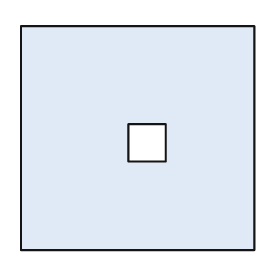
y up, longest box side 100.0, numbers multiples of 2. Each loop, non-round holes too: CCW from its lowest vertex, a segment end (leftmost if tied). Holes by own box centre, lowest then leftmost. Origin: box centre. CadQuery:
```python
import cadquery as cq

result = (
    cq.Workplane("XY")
    .moveTo(-50.0, -48.0)
    .lineTo(50.0, -48.0)
    .lineTo(50.0, 48.0)
    .lineTo(-50.0, 48.0)
    .close()
    .moveTo(-4.0, -10.0)
    .lineTo(12.0, -10.0)
    .lineTo(12.0, 6.0)
    .lineTo(-4.0, 6.0)
    .close()
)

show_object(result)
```